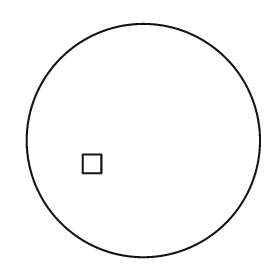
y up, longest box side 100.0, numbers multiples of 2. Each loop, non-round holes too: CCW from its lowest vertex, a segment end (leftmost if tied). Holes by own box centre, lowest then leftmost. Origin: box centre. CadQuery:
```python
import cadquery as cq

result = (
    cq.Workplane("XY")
    .moveTo(0.0, 0.0)
    .circle(50.0)
    .moveTo(-26.0, -14.0)
    .lineTo(-18.0, -14.0)
    .lineTo(-18.0, -6.0)
    .lineTo(-26.0, -6.0)
    .close()
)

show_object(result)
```